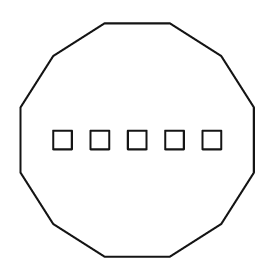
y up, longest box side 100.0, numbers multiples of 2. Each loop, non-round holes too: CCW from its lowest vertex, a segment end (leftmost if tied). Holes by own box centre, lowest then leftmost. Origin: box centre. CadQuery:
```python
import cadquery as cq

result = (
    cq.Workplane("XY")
    .moveTo(-14.0, -50.0)
    .lineTo(14.0, -50.0)
    .lineTo(36.0, -36.0)
    .lineTo(50.0, -14.0)
    .lineTo(50.0, 14.0)
    .lineTo(36.0, 36.0)
    .lineTo(14.0, 50.0)
    .lineTo(-14.0, 50.0)
    .lineTo(-36.0, 36.0)
    .lineTo(-50.0, 14.0)
    .lineTo(-50.0, -14.0)
    .lineTo(-36.0, -36.0)
    .close()
    .moveTo(-36.0, -4.0)
    .lineTo(-28.0, -4.0)
    .lineTo(-28.0, 4.0)
    .lineTo(-36.0, 4.0)
    .close()
    .moveTo(-20.0, -4.0)
    .lineTo(-12.0, -4.0)
    .lineTo(-12.0, 4.0)
    .lineTo(-20.0, 4.0)
    .close()
    .moveTo(-4.0, -4.0)
    .lineTo(4.0, -4.0)
    .lineTo(4.0, 4.0)
    .lineTo(-4.0, 4.0)
    .close()
    .moveTo(12.0, -4.0)
    .lineTo(20.0, -4.0)
    .lineTo(20.0, 4.0)
    .lineTo(12.0, 4.0)
    .close()
    .moveTo(28.0, -4.0)
    .lineTo(36.0, -4.0)
    .lineTo(36.0, 4.0)
    .lineTo(28.0, 4.0)
    .close()
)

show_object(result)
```